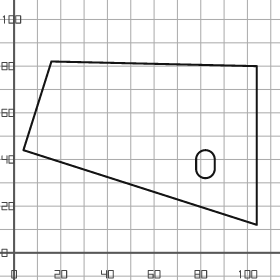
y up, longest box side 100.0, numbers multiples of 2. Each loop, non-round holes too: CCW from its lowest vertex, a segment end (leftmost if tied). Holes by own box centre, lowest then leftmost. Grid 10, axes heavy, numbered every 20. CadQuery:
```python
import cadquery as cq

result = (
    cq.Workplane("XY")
    .moveTo(104.0, 12.0)
    .lineTo(104.0, 80.0)
    .lineTo(16.0, 82.0)
    .lineTo(4.0, 44.0)
    .close()
    .moveTo(78.0, 36.0)
    .threePointArc((82.0, 32.0), (86.0, 36.0))
    .lineTo(86.0, 40.0)
    .threePointArc((82.0, 44.0), (78.0, 40.0))
    .close()
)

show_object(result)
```